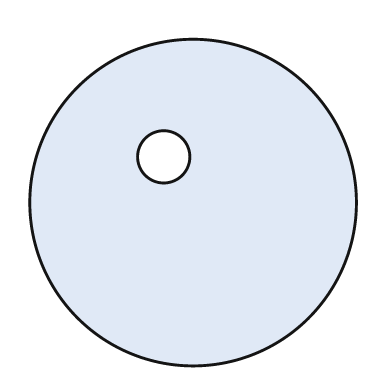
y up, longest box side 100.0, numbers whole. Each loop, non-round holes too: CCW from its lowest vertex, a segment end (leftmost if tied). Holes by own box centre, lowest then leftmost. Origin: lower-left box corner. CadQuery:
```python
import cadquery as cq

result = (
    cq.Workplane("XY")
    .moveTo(50.0, 50.0)
    .circle(50.0)
    .moveTo(41.0, 64.0)
    .circle(8.0)
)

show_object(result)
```